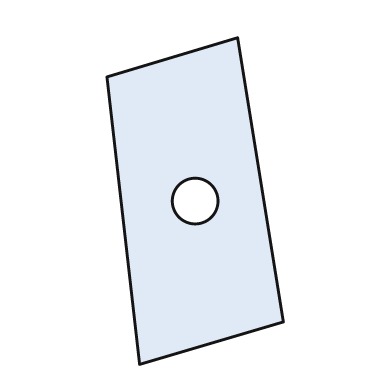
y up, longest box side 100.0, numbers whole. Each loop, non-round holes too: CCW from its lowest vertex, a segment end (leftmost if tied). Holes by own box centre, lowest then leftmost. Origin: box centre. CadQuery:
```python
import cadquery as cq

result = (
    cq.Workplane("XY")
    .moveTo(-17.0, -50.0)
    .lineTo(27.0, -37.0)
    .lineTo(13.0, 50.0)
    .lineTo(-27.0, 38.0)
    .close()
    .moveTo(0.0, 0.0)
    .circle(7.0)
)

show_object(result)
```